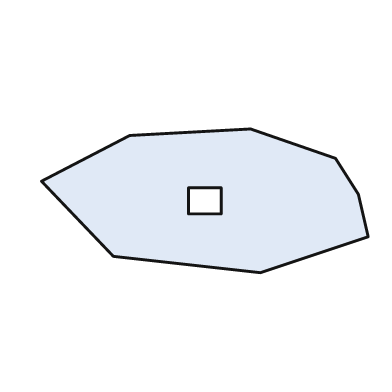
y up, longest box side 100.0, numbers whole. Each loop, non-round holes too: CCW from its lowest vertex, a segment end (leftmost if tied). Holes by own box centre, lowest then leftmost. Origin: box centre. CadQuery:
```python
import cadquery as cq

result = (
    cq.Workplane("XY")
    .moveTo(17.0, -22.0)
    .lineTo(50.0, -11.0)
    .lineTo(47.0, 2.0)
    .lineTo(40.0, 13.0)
    .lineTo(14.0, 22.0)
    .lineTo(-23.0, 20.0)
    .lineTo(-50.0, 6.0)
    .lineTo(-28.0, -17.0)
    .close()
    .moveTo(-5.0, -4.0)
    .lineTo(5.0, -4.0)
    .lineTo(5.0, 4.0)
    .lineTo(-5.0, 4.0)
    .close()
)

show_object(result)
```